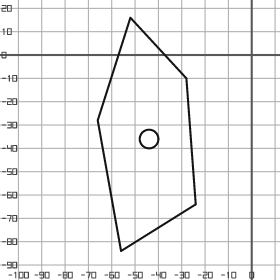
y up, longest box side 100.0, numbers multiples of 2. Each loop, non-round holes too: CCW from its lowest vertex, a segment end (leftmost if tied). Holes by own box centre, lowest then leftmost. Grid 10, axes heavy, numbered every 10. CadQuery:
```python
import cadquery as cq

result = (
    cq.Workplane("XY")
    .moveTo(-56.0, -84.0)
    .lineTo(-24.0, -64.0)
    .lineTo(-28.0, -10.0)
    .lineTo(-52.0, 16.0)
    .lineTo(-66.0, -28.0)
    .close()
    .moveTo(-44.0, -36.0)
    .circle(4.0)
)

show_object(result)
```